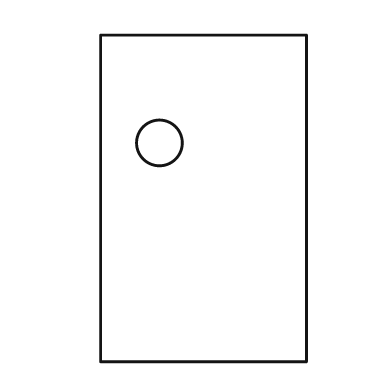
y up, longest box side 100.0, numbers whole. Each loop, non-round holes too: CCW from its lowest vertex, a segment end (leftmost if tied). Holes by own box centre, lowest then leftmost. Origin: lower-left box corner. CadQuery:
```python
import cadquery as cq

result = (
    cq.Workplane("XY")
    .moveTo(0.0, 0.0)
    .lineTo(63.0, 0.0)
    .lineTo(63.0, 100.0)
    .lineTo(0.0, 100.0)
    .close()
    .moveTo(18.0, 67.0)
    .circle(7.0)
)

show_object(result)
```